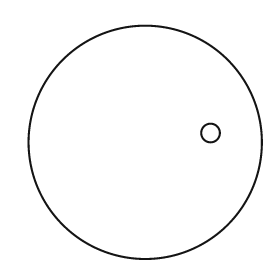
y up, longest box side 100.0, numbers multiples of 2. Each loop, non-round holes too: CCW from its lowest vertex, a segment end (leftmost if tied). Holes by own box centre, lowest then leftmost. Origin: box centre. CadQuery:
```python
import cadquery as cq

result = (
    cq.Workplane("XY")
    .moveTo(0.0, 0.0)
    .circle(50.0)
    .moveTo(28.0, 4.0)
    .circle(4.0)
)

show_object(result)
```